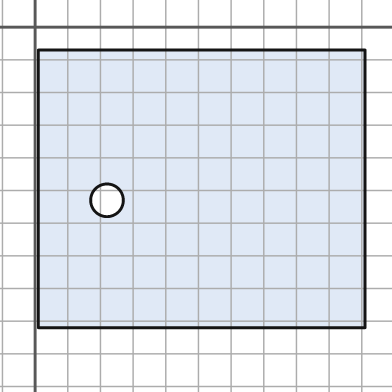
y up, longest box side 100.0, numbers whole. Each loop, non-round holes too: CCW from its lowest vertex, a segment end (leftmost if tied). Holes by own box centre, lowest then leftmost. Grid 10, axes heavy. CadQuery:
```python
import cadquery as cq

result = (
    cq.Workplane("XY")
    .moveTo(1.0, -92.0)
    .lineTo(101.0, -92.0)
    .lineTo(101.0, -7.0)
    .lineTo(1.0, -7.0)
    .close()
    .moveTo(22.0, -53.0)
    .circle(5.0)
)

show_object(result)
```